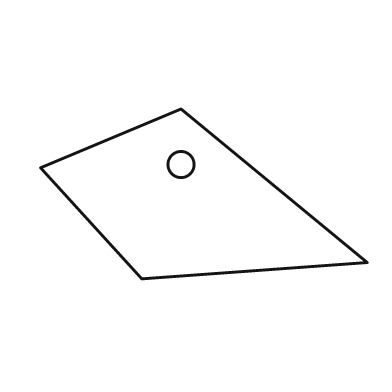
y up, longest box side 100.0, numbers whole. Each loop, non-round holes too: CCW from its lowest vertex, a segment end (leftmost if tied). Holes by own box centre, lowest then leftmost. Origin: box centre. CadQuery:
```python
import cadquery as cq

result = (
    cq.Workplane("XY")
    .moveTo(-19.0, -26.0)
    .lineTo(50.0, -21.0)
    .lineTo(-7.0, 26.0)
    .lineTo(-50.0, 8.0)
    .close()
    .moveTo(-7.0, 9.0)
    .circle(4.0)
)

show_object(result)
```